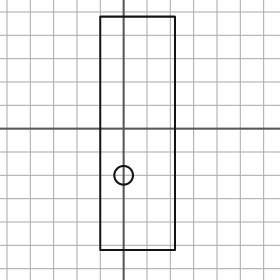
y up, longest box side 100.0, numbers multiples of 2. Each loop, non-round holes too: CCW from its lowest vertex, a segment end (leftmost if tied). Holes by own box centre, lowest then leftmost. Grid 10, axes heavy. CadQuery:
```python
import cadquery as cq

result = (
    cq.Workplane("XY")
    .moveTo(-10.0, -52.0)
    .lineTo(22.0, -52.0)
    .lineTo(22.0, 48.0)
    .lineTo(-10.0, 48.0)
    .close()
    .moveTo(0.0, -20.0)
    .circle(4.0)
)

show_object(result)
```